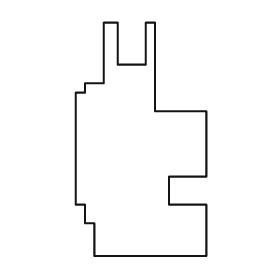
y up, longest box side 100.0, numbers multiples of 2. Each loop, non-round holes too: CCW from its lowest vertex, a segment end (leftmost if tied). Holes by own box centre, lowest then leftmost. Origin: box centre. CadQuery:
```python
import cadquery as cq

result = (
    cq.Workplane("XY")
    .moveTo(-20.0, -50.0)
    .lineTo(28.0, -50.0)
    .lineTo(28.0, -28.0)
    .lineTo(12.0, -28.0)
    .lineTo(12.0, -16.0)
    .lineTo(28.0, -16.0)
    .lineTo(28.0, 12.0)
    .lineTo(6.0, 12.0)
    .lineTo(6.0, 50.0)
    .lineTo(2.0, 50.0)
    .lineTo(2.0, 32.0)
    .lineTo(-10.0, 32.0)
    .lineTo(-10.0, 50.0)
    .lineTo(-16.0, 50.0)
    .lineTo(-16.0, 24.0)
    .lineTo(-24.0, 24.0)
    .lineTo(-24.0, 20.0)
    .lineTo(-28.0, 20.0)
    .lineTo(-28.0, -28.0)
    .lineTo(-24.0, -28.0)
    .lineTo(-24.0, -36.0)
    .lineTo(-20.0, -36.0)
    .close()
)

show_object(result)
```